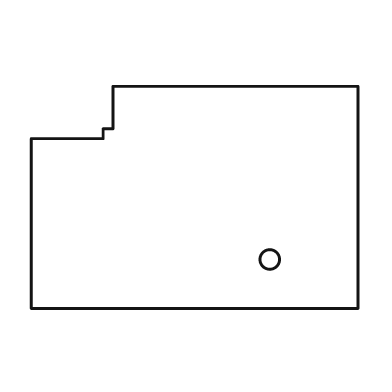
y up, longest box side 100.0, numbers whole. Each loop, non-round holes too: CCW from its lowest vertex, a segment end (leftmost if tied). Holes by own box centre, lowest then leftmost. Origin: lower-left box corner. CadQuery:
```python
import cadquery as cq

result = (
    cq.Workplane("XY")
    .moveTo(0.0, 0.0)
    .lineTo(100.0, 0.0)
    .lineTo(100.0, 68.0)
    .lineTo(25.0, 68.0)
    .lineTo(25.0, 55.0)
    .lineTo(22.0, 55.0)
    .lineTo(22.0, 52.0)
    .lineTo(0.0, 52.0)
    .close()
    .moveTo(73.0, 15.0)
    .circle(3.0)
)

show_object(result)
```